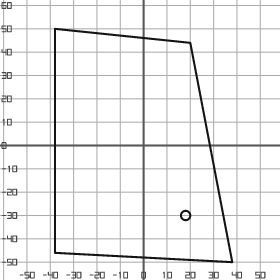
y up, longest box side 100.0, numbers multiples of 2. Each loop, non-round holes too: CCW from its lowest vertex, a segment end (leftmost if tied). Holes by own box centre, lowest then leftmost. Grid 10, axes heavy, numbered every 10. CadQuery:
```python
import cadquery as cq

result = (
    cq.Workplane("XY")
    .moveTo(38.0, -50.0)
    .lineTo(20.0, 44.0)
    .lineTo(-38.0, 50.0)
    .lineTo(-38.0, -46.0)
    .close()
    .moveTo(18.0, -30.0)
    .circle(2.0)
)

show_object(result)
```